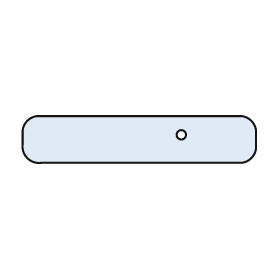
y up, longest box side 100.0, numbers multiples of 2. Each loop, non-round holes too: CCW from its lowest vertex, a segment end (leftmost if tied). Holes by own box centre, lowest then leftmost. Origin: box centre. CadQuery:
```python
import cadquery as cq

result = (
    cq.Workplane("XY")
    .moveTo(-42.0, -10.0)
    .lineTo(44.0, -10.0)
    .threePointArc((48.0, -8.0), (50.0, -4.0))
    .lineTo(50.0, 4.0)
    .threePointArc((48.0, 8.0), (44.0, 10.0))
    .lineTo(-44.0, 10.0)
    .threePointArc((-48.0, 8.0), (-50.0, 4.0))
    .lineTo(-50.0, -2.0)
    .threePointArc((-48.0, -8.0), (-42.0, -10.0))
    .close()
    .moveTo(18.0, 2.0)
    .circle(2.0)
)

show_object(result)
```